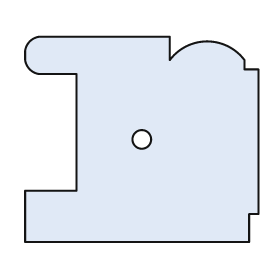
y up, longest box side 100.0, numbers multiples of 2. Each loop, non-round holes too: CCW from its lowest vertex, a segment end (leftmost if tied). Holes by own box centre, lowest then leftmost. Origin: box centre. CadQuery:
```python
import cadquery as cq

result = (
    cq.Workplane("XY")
    .moveTo(-50.0, -44.0)
    .lineTo(46.0, -44.0)
    .lineTo(46.0, -32.0)
    .lineTo(50.0, -32.0)
    .lineTo(50.0, 30.0)
    .lineTo(44.0, 30.0)
    .lineTo(44.0, 34.0)
    .threePointArc((28.0, 42.0), (12.0, 34.0))
    .lineTo(12.0, 44.0)
    .lineTo(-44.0, 44.0)
    .threePointArc((-48.0, 42.0), (-50.0, 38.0))
    .lineTo(-50.0, 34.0)
    .threePointArc((-48.0, 30.0), (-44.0, 28.0))
    .lineTo(-28.0, 28.0)
    .lineTo(-28.0, -22.0)
    .lineTo(-50.0, -22.0)
    .close()
    .moveTo(0.0, 0.0)
    .circle(4.0)
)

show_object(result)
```